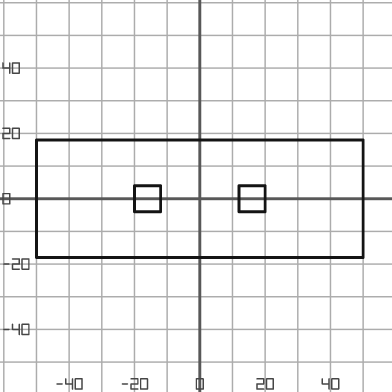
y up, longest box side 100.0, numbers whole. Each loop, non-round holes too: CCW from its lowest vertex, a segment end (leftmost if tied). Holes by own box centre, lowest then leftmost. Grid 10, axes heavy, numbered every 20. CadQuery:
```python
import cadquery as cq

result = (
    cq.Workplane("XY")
    .moveTo(-50.0, -18.0)
    .lineTo(50.0, -18.0)
    .lineTo(50.0, 18.0)
    .lineTo(-50.0, 18.0)
    .close()
    .moveTo(-20.0, -4.0)
    .lineTo(-12.0, -4.0)
    .lineTo(-12.0, 4.0)
    .lineTo(-20.0, 4.0)
    .close()
    .moveTo(12.0, -4.0)
    .lineTo(20.0, -4.0)
    .lineTo(20.0, 4.0)
    .lineTo(12.0, 4.0)
    .close()
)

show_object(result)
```